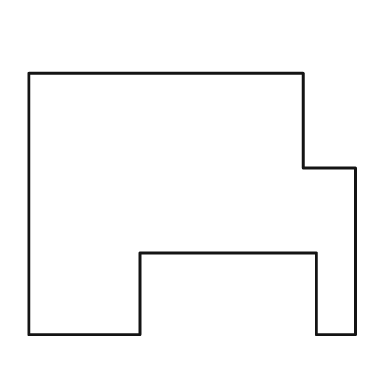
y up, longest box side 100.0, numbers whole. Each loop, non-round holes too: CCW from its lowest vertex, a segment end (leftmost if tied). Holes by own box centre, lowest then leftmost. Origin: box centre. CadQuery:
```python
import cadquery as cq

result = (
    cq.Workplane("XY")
    .moveTo(-50.0, -40.0)
    .lineTo(-16.0, -40.0)
    .lineTo(-16.0, -15.0)
    .lineTo(38.0, -15.0)
    .lineTo(38.0, -40.0)
    .lineTo(50.0, -40.0)
    .lineTo(50.0, 11.0)
    .lineTo(34.0, 11.0)
    .lineTo(34.0, 40.0)
    .lineTo(-50.0, 40.0)
    .close()
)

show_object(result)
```